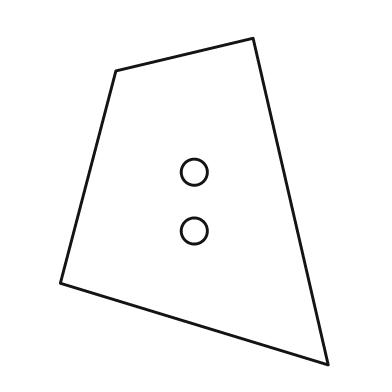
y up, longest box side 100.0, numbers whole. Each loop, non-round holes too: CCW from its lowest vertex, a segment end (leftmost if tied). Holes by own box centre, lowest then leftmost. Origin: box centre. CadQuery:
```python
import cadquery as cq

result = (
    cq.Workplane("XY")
    .moveTo(41.0, -50.0)
    .lineTo(18.0, 50.0)
    .lineTo(-24.0, 40.0)
    .lineTo(-41.0, -25.0)
    .close()
    .moveTo(0.0, -9.0)
    .circle(4.0)
    .moveTo(0.0, 9.0)
    .circle(4.0)
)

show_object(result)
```